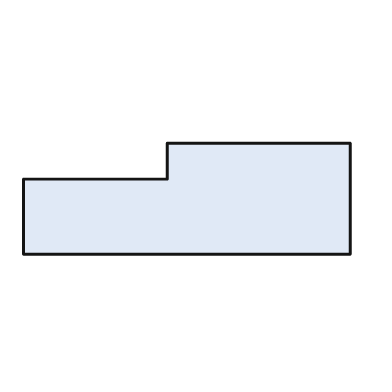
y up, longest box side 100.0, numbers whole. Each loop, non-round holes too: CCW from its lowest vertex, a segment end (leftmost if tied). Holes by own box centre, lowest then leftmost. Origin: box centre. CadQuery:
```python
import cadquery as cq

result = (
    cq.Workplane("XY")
    .moveTo(-50.0, -17.0)
    .lineTo(50.0, -17.0)
    .lineTo(50.0, 17.0)
    .lineTo(-6.0, 17.0)
    .lineTo(-6.0, 6.0)
    .lineTo(-50.0, 6.0)
    .close()
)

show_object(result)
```